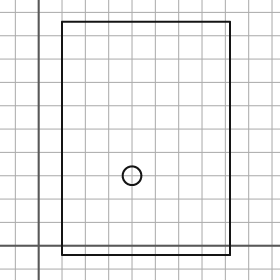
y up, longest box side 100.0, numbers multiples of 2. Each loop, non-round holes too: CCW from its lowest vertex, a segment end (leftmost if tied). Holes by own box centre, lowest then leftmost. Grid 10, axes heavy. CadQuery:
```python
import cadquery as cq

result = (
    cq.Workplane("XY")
    .moveTo(10.0, -4.0)
    .lineTo(82.0, -4.0)
    .lineTo(82.0, 96.0)
    .lineTo(10.0, 96.0)
    .close()
    .moveTo(40.0, 30.0)
    .circle(4.0)
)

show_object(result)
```